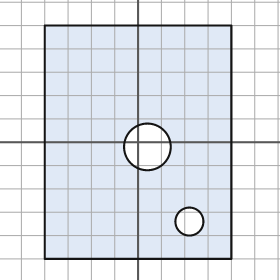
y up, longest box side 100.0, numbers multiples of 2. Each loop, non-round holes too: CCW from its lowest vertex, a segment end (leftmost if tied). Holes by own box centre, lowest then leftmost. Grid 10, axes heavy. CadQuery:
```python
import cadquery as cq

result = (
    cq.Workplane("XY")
    .moveTo(-40.0, -50.0)
    .lineTo(40.0, -50.0)
    .lineTo(40.0, 50.0)
    .lineTo(-40.0, 50.0)
    .close()
    .moveTo(22.0, -34.0)
    .circle(6.0)
    .moveTo(4.0, -2.0)
    .circle(10.0)
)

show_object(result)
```